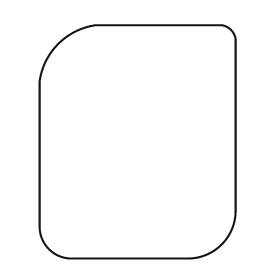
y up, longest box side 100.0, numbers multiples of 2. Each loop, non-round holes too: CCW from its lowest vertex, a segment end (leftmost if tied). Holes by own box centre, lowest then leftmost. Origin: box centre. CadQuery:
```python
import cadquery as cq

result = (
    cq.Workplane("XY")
    .moveTo(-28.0, -50.0)
    .lineTo(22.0, -50.0)
    .threePointArc((36.0, -44.0), (42.0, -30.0))
    .lineTo(42.0, 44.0)
    .threePointArc((40.0, 48.0), (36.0, 50.0))
    .lineTo(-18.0, 50.0)
    .threePointArc((-34.0, 42.0), (-42.0, 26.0))
    .lineTo(-42.0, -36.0)
    .threePointArc((-38.0, -46.0), (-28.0, -50.0))
    .close()
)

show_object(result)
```